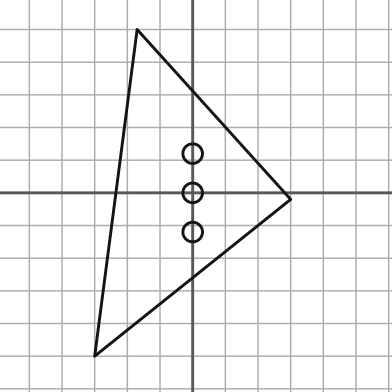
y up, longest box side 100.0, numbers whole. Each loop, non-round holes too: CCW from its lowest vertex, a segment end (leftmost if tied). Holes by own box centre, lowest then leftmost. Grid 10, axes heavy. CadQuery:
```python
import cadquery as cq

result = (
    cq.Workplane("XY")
    .moveTo(-30.0, -50.0)
    .lineTo(30.0, -2.0)
    .lineTo(-17.0, 50.0)
    .close()
    .moveTo(0.0, -12.0)
    .circle(3.0)
    .moveTo(0.0, 0.0)
    .circle(3.0)
    .moveTo(0.0, 12.0)
    .circle(3.0)
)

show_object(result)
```